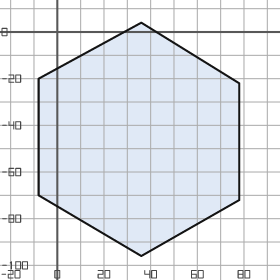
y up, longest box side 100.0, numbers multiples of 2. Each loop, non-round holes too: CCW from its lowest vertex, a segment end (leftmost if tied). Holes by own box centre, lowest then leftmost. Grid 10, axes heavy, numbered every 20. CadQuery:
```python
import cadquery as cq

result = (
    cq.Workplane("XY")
    .moveTo(36.0, -96.0)
    .lineTo(78.0, -72.0)
    .lineTo(78.0, -22.0)
    .lineTo(36.0, 4.0)
    .lineTo(-8.0, -20.0)
    .lineTo(-8.0, -70.0)
    .close()
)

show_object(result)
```